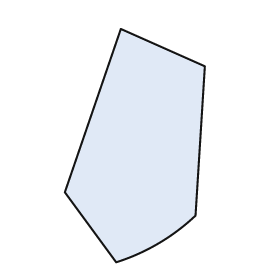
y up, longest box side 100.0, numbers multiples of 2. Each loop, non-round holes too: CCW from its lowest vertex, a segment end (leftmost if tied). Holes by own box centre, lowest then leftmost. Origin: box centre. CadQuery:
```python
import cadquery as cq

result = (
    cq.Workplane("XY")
    .moveTo(-8.0, -50.0)
    .threePointArc((10.0, -42.0), (26.0, -30.0))
    .lineTo(30.0, 34.0)
    .lineTo(-6.0, 50.0)
    .lineTo(-30.0, -20.0)
    .close()
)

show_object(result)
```